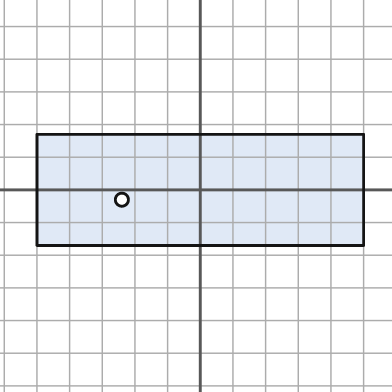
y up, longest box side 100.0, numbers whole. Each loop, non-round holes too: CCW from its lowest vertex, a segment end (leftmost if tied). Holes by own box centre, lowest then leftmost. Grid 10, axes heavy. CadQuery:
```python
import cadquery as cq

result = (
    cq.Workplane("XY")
    .moveTo(-50.0, -17.0)
    .lineTo(50.0, -17.0)
    .lineTo(50.0, 17.0)
    .lineTo(-50.0, 17.0)
    .close()
    .moveTo(-24.0, -3.0)
    .circle(2.0)
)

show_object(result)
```